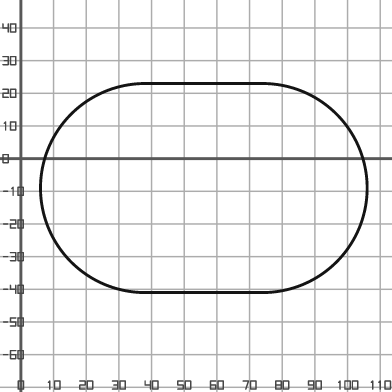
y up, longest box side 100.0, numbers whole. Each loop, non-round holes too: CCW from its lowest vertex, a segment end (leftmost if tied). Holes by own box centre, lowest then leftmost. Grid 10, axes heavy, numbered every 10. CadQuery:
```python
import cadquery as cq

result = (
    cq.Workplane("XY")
    .moveTo(38.0, -41.0)
    .lineTo(74.0, -41.0)
    .threePointArc((106.0, -9.0), (74.0, 23.0))
    .lineTo(38.0, 23.0)
    .threePointArc((6.0, -9.0), (38.0, -41.0))
    .close()
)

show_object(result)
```